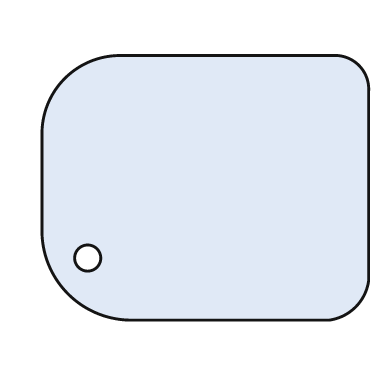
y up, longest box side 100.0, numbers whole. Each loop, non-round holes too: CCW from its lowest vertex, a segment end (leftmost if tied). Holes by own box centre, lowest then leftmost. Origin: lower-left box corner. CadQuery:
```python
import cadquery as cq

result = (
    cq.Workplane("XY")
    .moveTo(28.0, 0.0)
    .lineTo(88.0, 0.0)
    .threePointArc((96.0, 4.0), (100.0, 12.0))
    .lineTo(100.0, 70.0)
    .threePointArc((97.0, 78.0), (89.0, 81.0))
    .lineTo(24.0, 81.0)
    .threePointArc((7.0, 74.0), (0.0, 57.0))
    .lineTo(0.0, 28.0)
    .threePointArc((8.0, 8.0), (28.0, 0.0))
    .close()
    .moveTo(14.0, 19.0)
    .circle(4.0)
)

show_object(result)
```